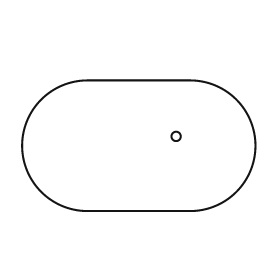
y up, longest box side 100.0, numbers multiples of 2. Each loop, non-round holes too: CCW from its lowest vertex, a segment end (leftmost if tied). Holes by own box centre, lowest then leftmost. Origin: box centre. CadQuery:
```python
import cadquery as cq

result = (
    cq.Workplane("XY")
    .moveTo(-22.0, -28.0)
    .lineTo(22.0, -28.0)
    .threePointArc((50.0, 0.0), (22.0, 28.0))
    .lineTo(-22.0, 28.0)
    .threePointArc((-50.0, 0.0), (-22.0, -28.0))
    .close()
    .moveTo(16.0, 4.0)
    .circle(2.0)
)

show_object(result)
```